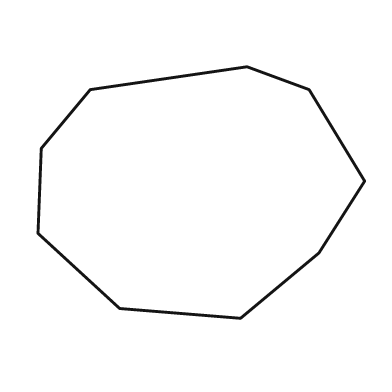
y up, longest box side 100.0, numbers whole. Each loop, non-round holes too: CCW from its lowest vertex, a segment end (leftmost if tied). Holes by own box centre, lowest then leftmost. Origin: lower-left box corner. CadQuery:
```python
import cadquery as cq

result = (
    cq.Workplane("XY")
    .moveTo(62.0, 0.0)
    .lineTo(86.0, 20.0)
    .lineTo(100.0, 42.0)
    .lineTo(83.0, 70.0)
    .lineTo(64.0, 77.0)
    .lineTo(16.0, 70.0)
    .lineTo(1.0, 52.0)
    .lineTo(0.0, 26.0)
    .lineTo(25.0, 3.0)
    .close()
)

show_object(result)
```